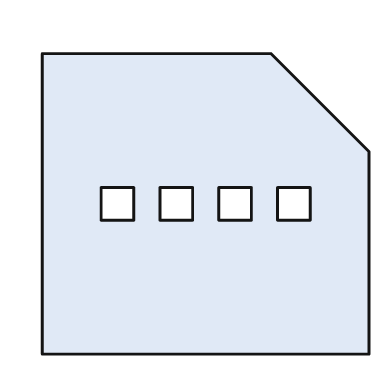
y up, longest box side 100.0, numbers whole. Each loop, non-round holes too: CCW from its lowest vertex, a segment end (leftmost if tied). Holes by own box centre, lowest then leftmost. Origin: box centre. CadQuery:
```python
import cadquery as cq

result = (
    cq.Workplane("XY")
    .moveTo(-50.0, -46.0)
    .lineTo(50.0, -46.0)
    .lineTo(50.0, 16.0)
    .lineTo(20.0, 46.0)
    .lineTo(-50.0, 46.0)
    .close()
    .moveTo(-32.0, -5.0)
    .lineTo(-22.0, -5.0)
    .lineTo(-22.0, 5.0)
    .lineTo(-32.0, 5.0)
    .close()
    .moveTo(-14.0, -5.0)
    .lineTo(-4.0, -5.0)
    .lineTo(-4.0, 5.0)
    .lineTo(-14.0, 5.0)
    .close()
    .moveTo(4.0, -5.0)
    .lineTo(14.0, -5.0)
    .lineTo(14.0, 5.0)
    .lineTo(4.0, 5.0)
    .close()
    .moveTo(22.0, -5.0)
    .lineTo(32.0, -5.0)
    .lineTo(32.0, 5.0)
    .lineTo(22.0, 5.0)
    .close()
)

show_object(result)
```